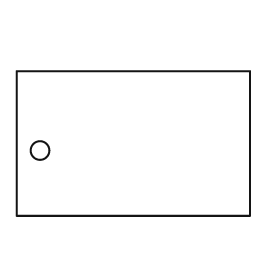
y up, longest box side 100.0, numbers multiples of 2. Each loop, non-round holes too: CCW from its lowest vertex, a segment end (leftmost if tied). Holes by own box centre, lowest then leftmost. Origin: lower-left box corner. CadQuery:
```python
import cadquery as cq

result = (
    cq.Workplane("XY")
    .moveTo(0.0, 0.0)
    .lineTo(100.0, 0.0)
    .lineTo(100.0, 62.0)
    .lineTo(0.0, 62.0)
    .close()
    .moveTo(10.0, 28.0)
    .circle(4.0)
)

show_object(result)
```